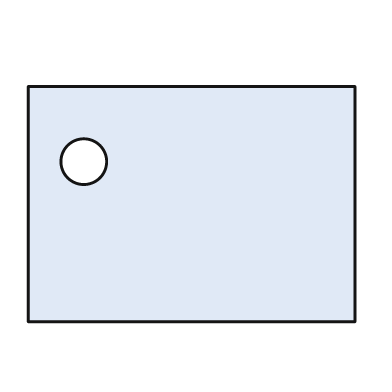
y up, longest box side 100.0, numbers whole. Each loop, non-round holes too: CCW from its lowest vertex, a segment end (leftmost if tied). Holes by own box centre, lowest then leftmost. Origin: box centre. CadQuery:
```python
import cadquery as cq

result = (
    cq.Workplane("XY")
    .moveTo(-50.0, -36.0)
    .lineTo(50.0, -36.0)
    .lineTo(50.0, 36.0)
    .lineTo(-50.0, 36.0)
    .close()
    .moveTo(-33.0, 13.0)
    .circle(7.0)
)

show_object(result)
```